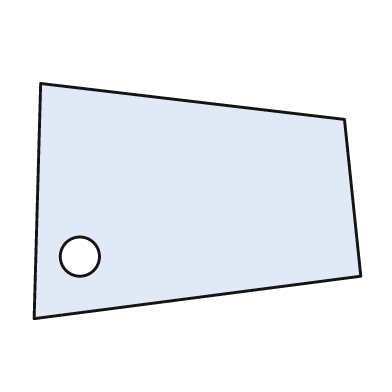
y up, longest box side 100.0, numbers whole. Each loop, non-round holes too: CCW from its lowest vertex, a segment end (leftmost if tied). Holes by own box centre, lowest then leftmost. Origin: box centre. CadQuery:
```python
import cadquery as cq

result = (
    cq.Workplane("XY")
    .moveTo(-50.0, -36.0)
    .lineTo(50.0, -23.0)
    .lineTo(45.0, 25.0)
    .lineTo(-48.0, 36.0)
    .close()
    .moveTo(-36.0, -17.0)
    .circle(6.0)
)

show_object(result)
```